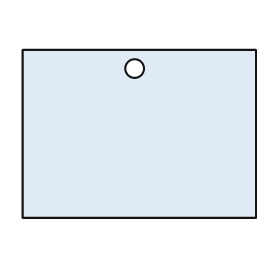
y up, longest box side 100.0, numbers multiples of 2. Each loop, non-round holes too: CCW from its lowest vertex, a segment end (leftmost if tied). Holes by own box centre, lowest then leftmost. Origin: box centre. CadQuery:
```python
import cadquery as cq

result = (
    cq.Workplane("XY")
    .moveTo(-50.0, -36.0)
    .lineTo(50.0, -36.0)
    .lineTo(50.0, 36.0)
    .lineTo(-50.0, 36.0)
    .close()
    .moveTo(-2.0, 28.0)
    .circle(4.0)
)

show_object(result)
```